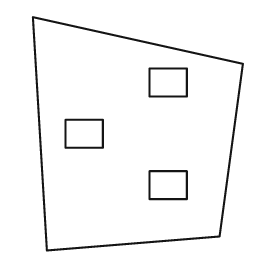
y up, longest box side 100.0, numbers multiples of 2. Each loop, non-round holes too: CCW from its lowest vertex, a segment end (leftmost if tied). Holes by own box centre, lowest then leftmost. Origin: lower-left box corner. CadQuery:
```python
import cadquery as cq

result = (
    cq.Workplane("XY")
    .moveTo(6.0, 0.0)
    .lineTo(80.0, 6.0)
    .lineTo(90.0, 80.0)
    .lineTo(0.0, 100.0)
    .close()
    .moveTo(50.0, 22.0)
    .lineTo(66.0, 22.0)
    .lineTo(66.0, 34.0)
    .lineTo(50.0, 34.0)
    .close()
    .moveTo(14.0, 44.0)
    .lineTo(30.0, 44.0)
    .lineTo(30.0, 56.0)
    .lineTo(14.0, 56.0)
    .close()
    .moveTo(50.0, 66.0)
    .lineTo(66.0, 66.0)
    .lineTo(66.0, 78.0)
    .lineTo(50.0, 78.0)
    .close()
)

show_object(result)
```